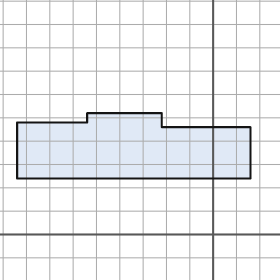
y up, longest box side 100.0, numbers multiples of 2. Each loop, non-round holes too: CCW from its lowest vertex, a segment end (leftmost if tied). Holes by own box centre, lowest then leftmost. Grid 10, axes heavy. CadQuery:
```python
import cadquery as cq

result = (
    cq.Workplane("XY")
    .moveTo(-84.0, 24.0)
    .lineTo(16.0, 24.0)
    .lineTo(16.0, 46.0)
    .lineTo(-22.0, 46.0)
    .lineTo(-22.0, 52.0)
    .lineTo(-54.0, 52.0)
    .lineTo(-54.0, 48.0)
    .lineTo(-84.0, 48.0)
    .close()
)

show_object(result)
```